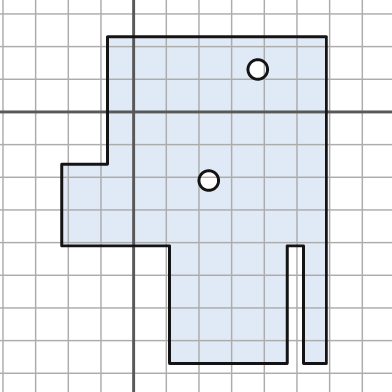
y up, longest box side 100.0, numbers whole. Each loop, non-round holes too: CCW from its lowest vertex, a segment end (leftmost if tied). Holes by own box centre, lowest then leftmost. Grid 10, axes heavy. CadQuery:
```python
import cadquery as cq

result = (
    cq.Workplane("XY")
    .moveTo(11.0, -77.0)
    .lineTo(47.0, -77.0)
    .lineTo(47.0, -41.0)
    .lineTo(52.0, -41.0)
    .lineTo(52.0, -77.0)
    .lineTo(59.0, -77.0)
    .lineTo(59.0, 23.0)
    .lineTo(-8.0, 23.0)
    .lineTo(-8.0, -16.0)
    .lineTo(-22.0, -16.0)
    .lineTo(-22.0, -41.0)
    .lineTo(11.0, -41.0)
    .close()
    .moveTo(23.0, -21.0)
    .circle(3.0)
    .moveTo(38.0, 13.0)
    .circle(3.0)
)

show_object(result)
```